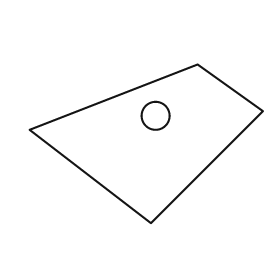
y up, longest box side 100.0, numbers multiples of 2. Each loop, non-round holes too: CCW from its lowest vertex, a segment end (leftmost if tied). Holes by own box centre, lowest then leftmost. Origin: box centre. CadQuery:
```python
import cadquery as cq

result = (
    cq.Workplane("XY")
    .moveTo(2.0, -34.0)
    .lineTo(50.0, 14.0)
    .lineTo(22.0, 34.0)
    .lineTo(-50.0, 6.0)
    .close()
    .moveTo(4.0, 12.0)
    .circle(6.0)
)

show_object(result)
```